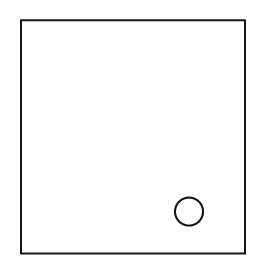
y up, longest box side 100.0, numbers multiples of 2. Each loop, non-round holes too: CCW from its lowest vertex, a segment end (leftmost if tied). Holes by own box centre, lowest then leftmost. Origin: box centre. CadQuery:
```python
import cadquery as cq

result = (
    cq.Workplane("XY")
    .moveTo(-48.0, -50.0)
    .lineTo(48.0, -50.0)
    .lineTo(48.0, 50.0)
    .lineTo(-48.0, 50.0)
    .close()
    .moveTo(24.0, -32.0)
    .circle(6.0)
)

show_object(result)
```